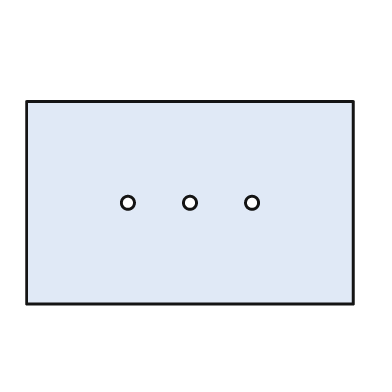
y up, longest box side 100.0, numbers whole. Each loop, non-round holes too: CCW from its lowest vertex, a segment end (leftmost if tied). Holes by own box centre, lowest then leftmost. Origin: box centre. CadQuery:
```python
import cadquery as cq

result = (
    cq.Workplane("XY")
    .moveTo(-50.0, -31.0)
    .lineTo(50.0, -31.0)
    .lineTo(50.0, 31.0)
    .lineTo(-50.0, 31.0)
    .close()
    .moveTo(-19.0, 0.0)
    .circle(2.0)
    .moveTo(0.0, 0.0)
    .circle(2.0)
    .moveTo(19.0, 0.0)
    .circle(2.0)
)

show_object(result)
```